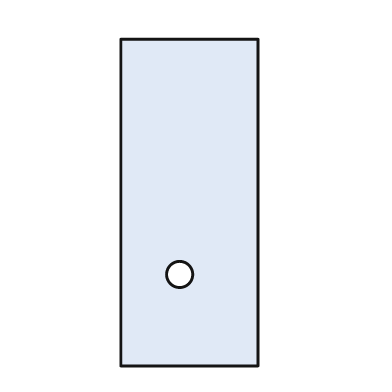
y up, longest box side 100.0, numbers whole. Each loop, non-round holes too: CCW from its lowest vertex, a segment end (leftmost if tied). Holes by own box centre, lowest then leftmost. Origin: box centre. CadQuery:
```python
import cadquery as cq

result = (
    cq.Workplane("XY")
    .moveTo(-21.0, -50.0)
    .lineTo(21.0, -50.0)
    .lineTo(21.0, 50.0)
    .lineTo(-21.0, 50.0)
    .close()
    .moveTo(-3.0, -22.0)
    .circle(4.0)
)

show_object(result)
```